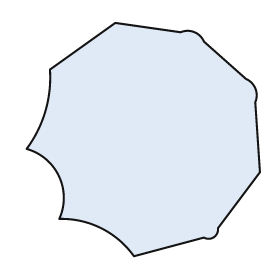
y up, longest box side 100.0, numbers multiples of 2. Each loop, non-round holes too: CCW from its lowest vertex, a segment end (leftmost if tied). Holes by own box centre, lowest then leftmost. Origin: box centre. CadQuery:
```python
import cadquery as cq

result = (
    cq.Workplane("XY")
    .moveTo(-4.0, -50.0)
    .lineTo(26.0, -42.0)
    .threePointArc((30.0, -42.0), (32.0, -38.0))
    .lineTo(50.0, -14.0)
    .lineTo(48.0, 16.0)
    .threePointArc((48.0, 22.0), (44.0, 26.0))
    .lineTo(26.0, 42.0)
    .threePointArc((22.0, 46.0), (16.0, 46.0))
    .lineTo(-12.0, 50.0)
    .lineTo(-40.0, 30.0)
    .threePointArc((-42.0, 12.0), (-50.0, -4.0))
    .threePointArc((-36.0, -16.0), (-36.0, -34.0))
    .threePointArc((-18.0, -38.0), (-4.0, -50.0))
    .close()
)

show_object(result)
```